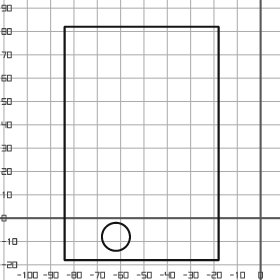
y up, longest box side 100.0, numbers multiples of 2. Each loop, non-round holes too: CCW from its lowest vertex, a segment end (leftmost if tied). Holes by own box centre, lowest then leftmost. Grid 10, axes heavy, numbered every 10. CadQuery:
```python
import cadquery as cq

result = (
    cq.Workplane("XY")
    .moveTo(-84.0, -18.0)
    .lineTo(-18.0, -18.0)
    .lineTo(-18.0, 82.0)
    .lineTo(-84.0, 82.0)
    .close()
    .moveTo(-62.0, -8.0)
    .circle(6.0)
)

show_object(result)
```